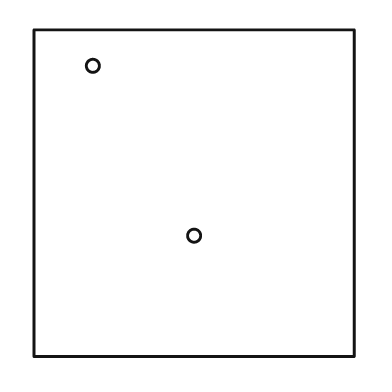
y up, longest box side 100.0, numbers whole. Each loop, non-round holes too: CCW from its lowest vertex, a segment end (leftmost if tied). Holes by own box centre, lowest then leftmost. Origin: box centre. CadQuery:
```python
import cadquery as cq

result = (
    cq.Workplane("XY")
    .moveTo(-49.0, -50.0)
    .lineTo(49.0, -50.0)
    .lineTo(49.0, 50.0)
    .lineTo(-49.0, 50.0)
    .close()
    .moveTo(0.0, -13.0)
    .circle(2.0)
    .moveTo(-31.0, 39.0)
    .circle(2.0)
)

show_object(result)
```